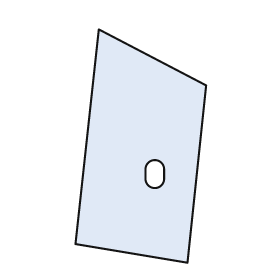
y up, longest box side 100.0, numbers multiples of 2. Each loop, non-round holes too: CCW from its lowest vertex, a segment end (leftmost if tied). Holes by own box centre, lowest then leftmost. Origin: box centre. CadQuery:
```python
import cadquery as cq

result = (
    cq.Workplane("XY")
    .moveTo(20.0, -50.0)
    .lineTo(28.0, 26.0)
    .lineTo(-18.0, 50.0)
    .lineTo(-28.0, -42.0)
    .close()
    .moveTo(2.0, -14.0)
    .threePointArc((6.0, -18.0), (10.0, -14.0))
    .lineTo(10.0, -10.0)
    .threePointArc((6.0, -6.0), (2.0, -10.0))
    .close()
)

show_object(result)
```